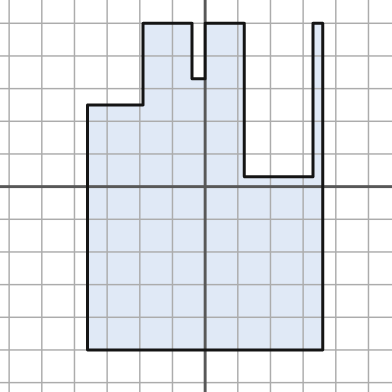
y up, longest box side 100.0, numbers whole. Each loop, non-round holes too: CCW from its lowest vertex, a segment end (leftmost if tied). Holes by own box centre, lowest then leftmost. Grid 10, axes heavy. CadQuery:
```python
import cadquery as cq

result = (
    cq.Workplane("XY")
    .moveTo(-36.0, -50.0)
    .lineTo(36.0, -50.0)
    .lineTo(36.0, 50.0)
    .lineTo(33.0, 50.0)
    .lineTo(33.0, 3.0)
    .lineTo(12.0, 3.0)
    .lineTo(12.0, 50.0)
    .lineTo(0.0, 50.0)
    .lineTo(0.0, 33.0)
    .lineTo(-4.0, 33.0)
    .lineTo(-4.0, 50.0)
    .lineTo(-19.0, 50.0)
    .lineTo(-19.0, 25.0)
    .lineTo(-36.0, 25.0)
    .close()
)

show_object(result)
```